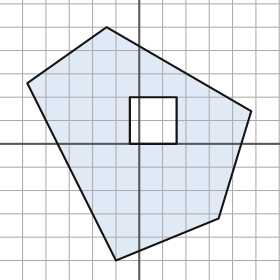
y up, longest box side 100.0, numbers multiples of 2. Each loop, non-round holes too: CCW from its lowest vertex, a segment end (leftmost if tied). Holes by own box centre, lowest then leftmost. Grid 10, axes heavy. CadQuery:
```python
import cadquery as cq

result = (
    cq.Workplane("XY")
    .moveTo(-10.0, -50.0)
    .lineTo(34.0, -32.0)
    .lineTo(48.0, 14.0)
    .lineTo(-14.0, 50.0)
    .lineTo(-48.0, 26.0)
    .close()
    .moveTo(-4.0, 0.0)
    .lineTo(16.0, 0.0)
    .lineTo(16.0, 20.0)
    .lineTo(-4.0, 20.0)
    .close()
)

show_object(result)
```